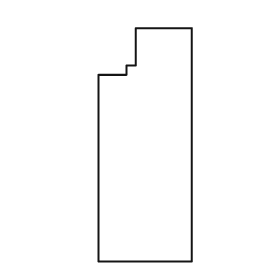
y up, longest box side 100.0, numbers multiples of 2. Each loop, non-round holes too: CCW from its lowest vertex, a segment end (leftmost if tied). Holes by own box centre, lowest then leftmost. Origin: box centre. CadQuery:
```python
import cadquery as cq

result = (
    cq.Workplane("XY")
    .moveTo(-20.0, -50.0)
    .lineTo(20.0, -50.0)
    .lineTo(20.0, 50.0)
    .lineTo(-4.0, 50.0)
    .lineTo(-4.0, 34.0)
    .lineTo(-8.0, 34.0)
    .lineTo(-8.0, 30.0)
    .lineTo(-20.0, 30.0)
    .close()
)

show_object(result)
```